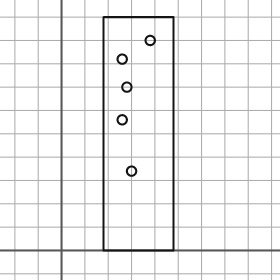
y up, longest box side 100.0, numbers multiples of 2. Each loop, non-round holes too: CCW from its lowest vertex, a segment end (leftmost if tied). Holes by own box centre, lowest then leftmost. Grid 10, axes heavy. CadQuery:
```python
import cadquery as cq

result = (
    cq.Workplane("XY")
    .moveTo(18.0, 0.0)
    .lineTo(48.0, 0.0)
    .lineTo(48.0, 100.0)
    .lineTo(18.0, 100.0)
    .close()
    .moveTo(30.0, 34.0)
    .circle(2.0)
    .moveTo(26.0, 56.0)
    .circle(2.0)
    .moveTo(28.0, 70.0)
    .circle(2.0)
    .moveTo(26.0, 82.0)
    .circle(2.0)
    .moveTo(38.0, 90.0)
    .circle(2.0)
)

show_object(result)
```